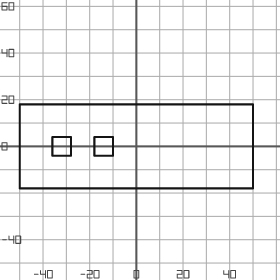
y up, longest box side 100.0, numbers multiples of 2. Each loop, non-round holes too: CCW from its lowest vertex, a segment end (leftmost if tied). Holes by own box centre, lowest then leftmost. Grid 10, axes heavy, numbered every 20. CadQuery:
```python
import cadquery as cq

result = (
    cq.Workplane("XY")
    .moveTo(-50.0, -18.0)
    .lineTo(50.0, -18.0)
    .lineTo(50.0, 18.0)
    .lineTo(-50.0, 18.0)
    .close()
    .moveTo(-36.0, -4.0)
    .lineTo(-28.0, -4.0)
    .lineTo(-28.0, 4.0)
    .lineTo(-36.0, 4.0)
    .close()
    .moveTo(-18.0, -4.0)
    .lineTo(-10.0, -4.0)
    .lineTo(-10.0, 4.0)
    .lineTo(-18.0, 4.0)
    .close()
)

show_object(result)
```